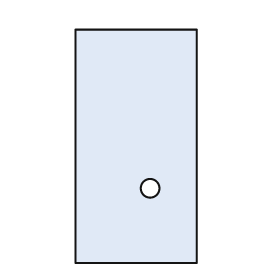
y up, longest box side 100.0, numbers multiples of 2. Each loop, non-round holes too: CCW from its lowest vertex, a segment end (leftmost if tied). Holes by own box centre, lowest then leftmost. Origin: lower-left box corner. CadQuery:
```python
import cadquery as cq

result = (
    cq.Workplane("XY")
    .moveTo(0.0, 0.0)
    .lineTo(52.0, 0.0)
    .lineTo(52.0, 100.0)
    .lineTo(0.0, 100.0)
    .close()
    .moveTo(32.0, 32.0)
    .circle(4.0)
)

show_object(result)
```